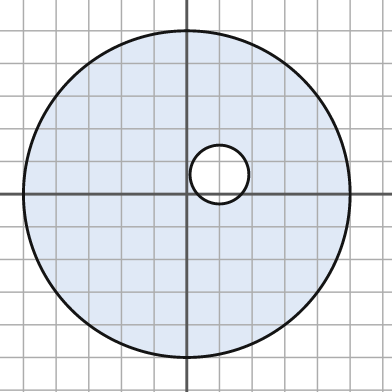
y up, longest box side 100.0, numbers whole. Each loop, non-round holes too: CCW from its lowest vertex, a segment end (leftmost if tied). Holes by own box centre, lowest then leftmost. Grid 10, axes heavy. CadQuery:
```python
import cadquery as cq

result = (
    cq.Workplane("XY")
    .moveTo(0.0, 0.0)
    .circle(50.0)
    .moveTo(10.0, 6.0)
    .circle(9.0)
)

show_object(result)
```